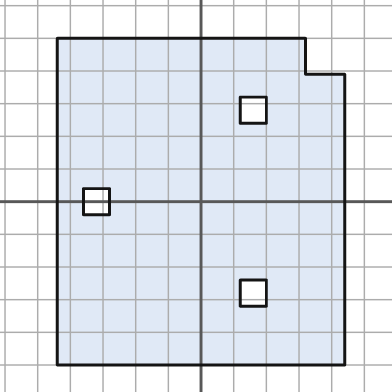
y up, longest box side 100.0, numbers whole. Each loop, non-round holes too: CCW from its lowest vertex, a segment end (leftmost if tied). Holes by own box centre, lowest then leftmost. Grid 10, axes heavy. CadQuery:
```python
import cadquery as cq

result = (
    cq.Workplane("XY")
    .moveTo(-44.0, -50.0)
    .lineTo(44.0, -50.0)
    .lineTo(44.0, 39.0)
    .lineTo(32.0, 39.0)
    .lineTo(32.0, 50.0)
    .lineTo(-44.0, 50.0)
    .close()
    .moveTo(12.0, -32.0)
    .lineTo(20.0, -32.0)
    .lineTo(20.0, -24.0)
    .lineTo(12.0, -24.0)
    .close()
    .moveTo(-36.0, -4.0)
    .lineTo(-28.0, -4.0)
    .lineTo(-28.0, 4.0)
    .lineTo(-36.0, 4.0)
    .close()
    .moveTo(12.0, 24.0)
    .lineTo(20.0, 24.0)
    .lineTo(20.0, 32.0)
    .lineTo(12.0, 32.0)
    .close()
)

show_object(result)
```